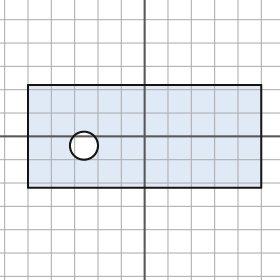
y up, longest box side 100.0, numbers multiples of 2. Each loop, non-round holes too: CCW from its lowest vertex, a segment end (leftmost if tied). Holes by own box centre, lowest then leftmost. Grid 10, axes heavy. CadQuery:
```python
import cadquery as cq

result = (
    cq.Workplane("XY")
    .moveTo(-50.0, -22.0)
    .lineTo(50.0, -22.0)
    .lineTo(50.0, 22.0)
    .lineTo(-50.0, 22.0)
    .close()
    .moveTo(-26.0, -4.0)
    .circle(6.0)
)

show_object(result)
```